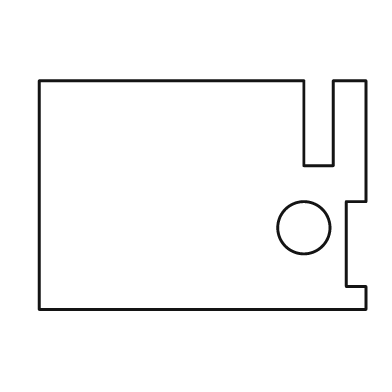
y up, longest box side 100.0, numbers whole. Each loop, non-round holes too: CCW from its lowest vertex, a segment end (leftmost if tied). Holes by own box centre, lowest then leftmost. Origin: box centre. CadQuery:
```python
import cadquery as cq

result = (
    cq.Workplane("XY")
    .moveTo(-50.0, -35.0)
    .lineTo(50.0, -35.0)
    .lineTo(50.0, -28.0)
    .lineTo(44.0, -28.0)
    .lineTo(44.0, -2.0)
    .lineTo(50.0, -2.0)
    .lineTo(50.0, 35.0)
    .lineTo(40.0, 35.0)
    .lineTo(40.0, 9.0)
    .lineTo(31.0, 9.0)
    .lineTo(31.0, 35.0)
    .lineTo(-50.0, 35.0)
    .close()
    .moveTo(31.0, -10.0)
    .circle(8.0)
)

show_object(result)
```